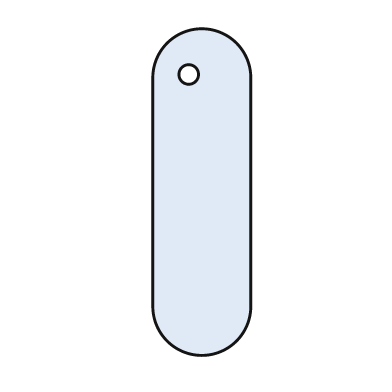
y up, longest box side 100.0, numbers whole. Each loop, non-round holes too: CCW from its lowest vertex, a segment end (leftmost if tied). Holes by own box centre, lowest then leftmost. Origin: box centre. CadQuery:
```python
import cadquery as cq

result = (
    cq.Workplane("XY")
    .moveTo(-15.0, -35.0)
    .threePointArc((0.0, -50.0), (15.0, -35.0))
    .lineTo(15.0, 35.0)
    .threePointArc((0.0, 50.0), (-15.0, 35.0))
    .close()
    .moveTo(-4.0, 36.0)
    .circle(3.0)
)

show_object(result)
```